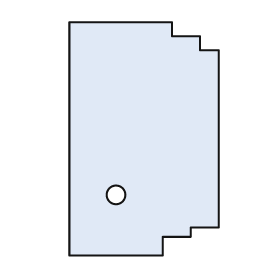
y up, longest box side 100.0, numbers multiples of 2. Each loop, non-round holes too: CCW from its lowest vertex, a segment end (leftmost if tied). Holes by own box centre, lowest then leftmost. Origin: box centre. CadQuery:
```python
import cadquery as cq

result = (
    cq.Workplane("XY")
    .moveTo(-32.0, -50.0)
    .lineTo(8.0, -50.0)
    .lineTo(8.0, -42.0)
    .lineTo(20.0, -42.0)
    .lineTo(20.0, -38.0)
    .lineTo(32.0, -38.0)
    .lineTo(32.0, 38.0)
    .lineTo(24.0, 38.0)
    .lineTo(24.0, 44.0)
    .lineTo(12.0, 44.0)
    .lineTo(12.0, 50.0)
    .lineTo(-32.0, 50.0)
    .close()
    .moveTo(-12.0, -24.0)
    .circle(4.0)
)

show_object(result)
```